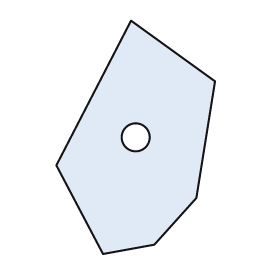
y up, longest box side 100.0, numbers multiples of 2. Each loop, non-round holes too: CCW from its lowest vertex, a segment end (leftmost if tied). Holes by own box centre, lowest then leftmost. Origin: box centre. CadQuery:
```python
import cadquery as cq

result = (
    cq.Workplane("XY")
    .moveTo(-14.0, -50.0)
    .lineTo(8.0, -46.0)
    .lineTo(26.0, -26.0)
    .lineTo(34.0, 24.0)
    .lineTo(-2.0, 50.0)
    .lineTo(-34.0, -12.0)
    .close()
    .moveTo(0.0, 0.0)
    .circle(6.0)
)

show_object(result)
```